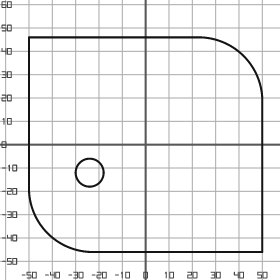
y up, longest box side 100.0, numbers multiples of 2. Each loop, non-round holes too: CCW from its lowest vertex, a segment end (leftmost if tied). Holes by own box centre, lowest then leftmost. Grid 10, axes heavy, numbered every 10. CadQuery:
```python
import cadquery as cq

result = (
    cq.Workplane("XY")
    .moveTo(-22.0, -46.0)
    .lineTo(50.0, -46.0)
    .lineTo(50.0, 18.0)
    .threePointArc((42.0, 38.0), (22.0, 46.0))
    .lineTo(-50.0, 46.0)
    .lineTo(-50.0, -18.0)
    .threePointArc((-42.0, -38.0), (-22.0, -46.0))
    .close()
    .moveTo(-24.0, -12.0)
    .circle(6.0)
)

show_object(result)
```